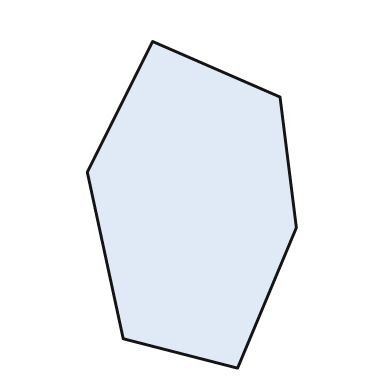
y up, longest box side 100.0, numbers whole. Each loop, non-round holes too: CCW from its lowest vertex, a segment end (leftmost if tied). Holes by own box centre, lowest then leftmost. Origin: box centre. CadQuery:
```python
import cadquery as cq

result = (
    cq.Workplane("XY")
    .moveTo(14.0, -50.0)
    .lineTo(32.0, -7.0)
    .lineTo(27.0, 33.0)
    .lineTo(-12.0, 50.0)
    .lineTo(-32.0, 10.0)
    .lineTo(-21.0, -41.0)
    .close()
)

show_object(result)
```